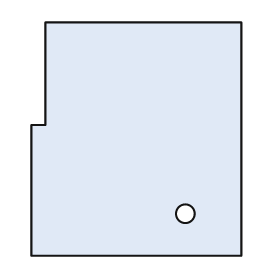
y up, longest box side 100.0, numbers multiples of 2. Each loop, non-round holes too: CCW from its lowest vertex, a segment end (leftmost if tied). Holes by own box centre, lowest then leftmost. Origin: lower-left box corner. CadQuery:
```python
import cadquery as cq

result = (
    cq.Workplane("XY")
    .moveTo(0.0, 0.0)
    .lineTo(90.0, 0.0)
    .lineTo(90.0, 100.0)
    .lineTo(6.0, 100.0)
    .lineTo(6.0, 56.0)
    .lineTo(0.0, 56.0)
    .close()
    .moveTo(66.0, 18.0)
    .circle(4.0)
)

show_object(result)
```